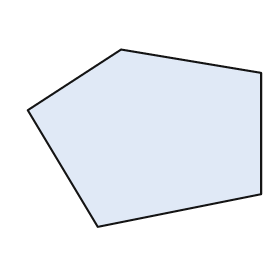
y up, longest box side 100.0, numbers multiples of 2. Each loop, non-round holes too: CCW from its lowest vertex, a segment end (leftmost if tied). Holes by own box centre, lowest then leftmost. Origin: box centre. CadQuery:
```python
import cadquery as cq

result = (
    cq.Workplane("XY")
    .moveTo(-20.0, -38.0)
    .lineTo(50.0, -24.0)
    .lineTo(50.0, 28.0)
    .lineTo(-10.0, 38.0)
    .lineTo(-50.0, 12.0)
    .close()
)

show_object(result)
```